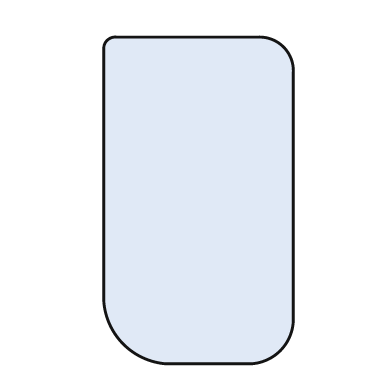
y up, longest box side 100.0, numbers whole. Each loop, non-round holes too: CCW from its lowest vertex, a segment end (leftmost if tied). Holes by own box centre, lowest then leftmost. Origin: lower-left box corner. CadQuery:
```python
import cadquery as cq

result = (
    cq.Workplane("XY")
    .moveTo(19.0, 0.0)
    .lineTo(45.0, 0.0)
    .threePointArc((54.0, 4.0), (58.0, 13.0))
    .lineTo(58.0, 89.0)
    .threePointArc((55.0, 97.0), (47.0, 100.0))
    .lineTo(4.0, 100.0)
    .threePointArc((1.0, 99.0), (0.0, 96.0))
    .lineTo(0.0, 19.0)
    .threePointArc((6.0, 6.0), (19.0, 0.0))
    .close()
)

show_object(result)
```